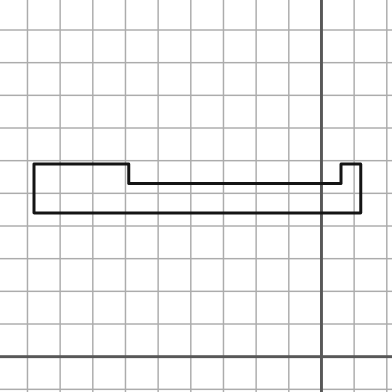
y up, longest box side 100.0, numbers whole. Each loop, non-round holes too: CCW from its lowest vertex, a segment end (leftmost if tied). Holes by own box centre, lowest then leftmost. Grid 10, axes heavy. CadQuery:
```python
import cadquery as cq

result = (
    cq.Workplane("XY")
    .moveTo(-88.0, 44.0)
    .lineTo(12.0, 44.0)
    .lineTo(12.0, 59.0)
    .lineTo(6.0, 59.0)
    .lineTo(6.0, 53.0)
    .lineTo(-59.0, 53.0)
    .lineTo(-59.0, 59.0)
    .lineTo(-88.0, 59.0)
    .close()
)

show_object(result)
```